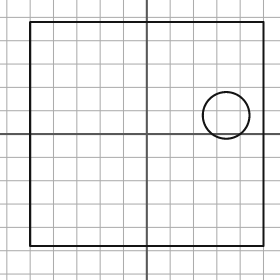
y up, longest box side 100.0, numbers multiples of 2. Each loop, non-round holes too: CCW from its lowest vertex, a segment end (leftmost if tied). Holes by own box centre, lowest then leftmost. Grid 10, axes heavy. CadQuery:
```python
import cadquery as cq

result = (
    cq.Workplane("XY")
    .moveTo(-50.0, -48.0)
    .lineTo(50.0, -48.0)
    .lineTo(50.0, 48.0)
    .lineTo(-50.0, 48.0)
    .close()
    .moveTo(34.0, 8.0)
    .circle(10.0)
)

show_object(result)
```